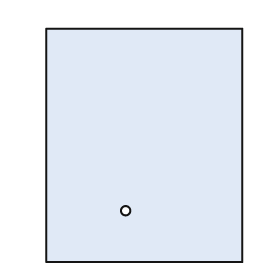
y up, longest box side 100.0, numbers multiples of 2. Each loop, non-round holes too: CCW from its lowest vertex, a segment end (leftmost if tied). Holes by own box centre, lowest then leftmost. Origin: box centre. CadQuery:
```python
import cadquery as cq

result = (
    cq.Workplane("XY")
    .moveTo(-42.0, -50.0)
    .lineTo(42.0, -50.0)
    .lineTo(42.0, 50.0)
    .lineTo(-42.0, 50.0)
    .close()
    .moveTo(-8.0, -28.0)
    .circle(2.0)
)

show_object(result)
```